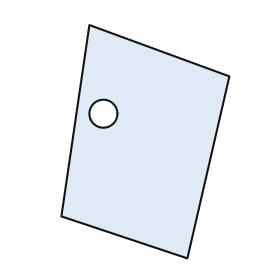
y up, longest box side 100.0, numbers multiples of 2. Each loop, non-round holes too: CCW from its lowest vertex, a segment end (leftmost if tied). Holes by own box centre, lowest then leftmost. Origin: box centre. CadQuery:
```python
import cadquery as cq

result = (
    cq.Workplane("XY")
    .moveTo(18.0, -50.0)
    .lineTo(36.0, 28.0)
    .lineTo(-24.0, 50.0)
    .lineTo(-36.0, -32.0)
    .close()
    .moveTo(-18.0, 12.0)
    .circle(6.0)
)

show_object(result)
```